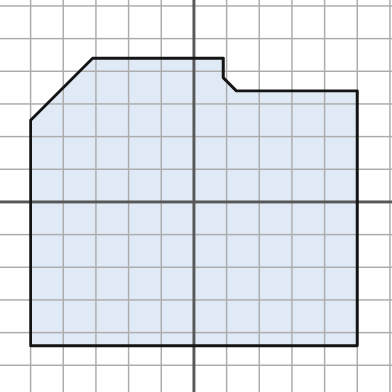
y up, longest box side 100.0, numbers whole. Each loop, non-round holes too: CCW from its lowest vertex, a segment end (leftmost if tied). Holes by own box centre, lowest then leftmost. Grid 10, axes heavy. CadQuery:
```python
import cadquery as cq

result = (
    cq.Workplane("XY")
    .moveTo(-50.0, -44.0)
    .lineTo(50.0, -44.0)
    .lineTo(50.0, 34.0)
    .lineTo(13.0, 34.0)
    .lineTo(9.0, 38.0)
    .lineTo(9.0, 44.0)
    .lineTo(-31.0, 44.0)
    .lineTo(-50.0, 25.0)
    .close()
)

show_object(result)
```